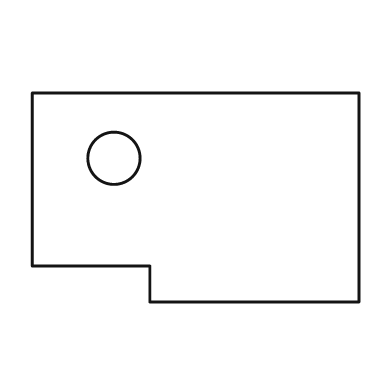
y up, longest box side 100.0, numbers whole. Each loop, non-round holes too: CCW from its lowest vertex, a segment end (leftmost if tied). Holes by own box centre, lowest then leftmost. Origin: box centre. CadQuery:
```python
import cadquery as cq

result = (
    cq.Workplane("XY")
    .moveTo(-14.0, -32.0)
    .lineTo(50.0, -32.0)
    .lineTo(50.0, 32.0)
    .lineTo(-50.0, 32.0)
    .lineTo(-50.0, -21.0)
    .lineTo(-14.0, -21.0)
    .close()
    .moveTo(-25.0, 12.0)
    .circle(8.0)
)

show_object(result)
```